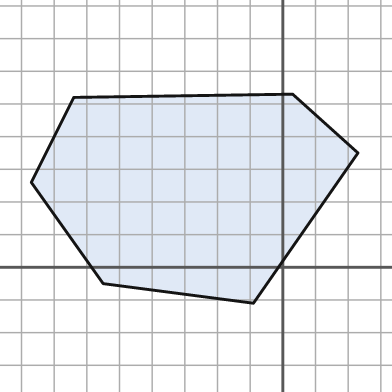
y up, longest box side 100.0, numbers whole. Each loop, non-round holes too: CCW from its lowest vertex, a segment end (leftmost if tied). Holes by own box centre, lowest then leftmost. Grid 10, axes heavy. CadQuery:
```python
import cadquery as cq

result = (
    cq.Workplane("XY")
    .moveTo(-9.0, -11.0)
    .lineTo(23.0, 35.0)
    .lineTo(3.0, 53.0)
    .lineTo(-64.0, 52.0)
    .lineTo(-77.0, 26.0)
    .lineTo(-55.0, -5.0)
    .close()
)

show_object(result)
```